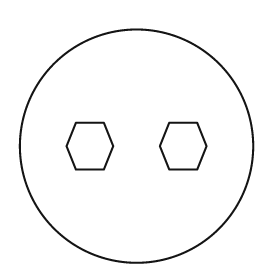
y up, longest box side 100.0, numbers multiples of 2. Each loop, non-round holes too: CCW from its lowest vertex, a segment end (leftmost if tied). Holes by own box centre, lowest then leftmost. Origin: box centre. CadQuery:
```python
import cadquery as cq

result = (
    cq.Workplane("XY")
    .moveTo(0.0, 0.0)
    .circle(50.0)
    .moveTo(-26.0, -10.0)
    .lineTo(-14.0, -10.0)
    .lineTo(-10.0, 0.0)
    .lineTo(-14.0, 10.0)
    .lineTo(-26.0, 10.0)
    .lineTo(-30.0, 0.0)
    .close()
    .moveTo(14.0, -10.0)
    .lineTo(26.0, -10.0)
    .lineTo(30.0, 0.0)
    .lineTo(26.0, 10.0)
    .lineTo(14.0, 10.0)
    .lineTo(10.0, 0.0)
    .close()
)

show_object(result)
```